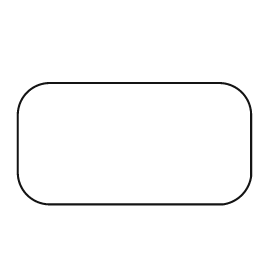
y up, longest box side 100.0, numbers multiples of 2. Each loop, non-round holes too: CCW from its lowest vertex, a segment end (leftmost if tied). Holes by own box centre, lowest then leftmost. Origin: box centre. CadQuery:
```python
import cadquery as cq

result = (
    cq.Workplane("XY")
    .moveTo(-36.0, -26.0)
    .lineTo(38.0, -26.0)
    .threePointArc((46.0, -22.0), (50.0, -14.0))
    .lineTo(50.0, 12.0)
    .threePointArc((46.0, 22.0), (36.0, 26.0))
    .lineTo(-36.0, 26.0)
    .threePointArc((-46.0, 22.0), (-50.0, 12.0))
    .lineTo(-50.0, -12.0)
    .threePointArc((-46.0, -22.0), (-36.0, -26.0))
    .close()
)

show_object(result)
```